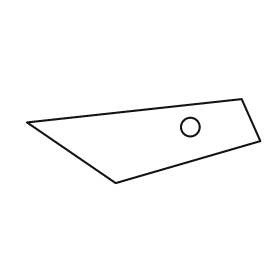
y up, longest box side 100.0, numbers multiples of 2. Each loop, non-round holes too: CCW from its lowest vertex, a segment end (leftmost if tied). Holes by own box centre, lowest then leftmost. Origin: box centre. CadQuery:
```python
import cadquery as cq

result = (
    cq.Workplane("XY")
    .moveTo(-12.0, -18.0)
    .lineTo(50.0, 0.0)
    .lineTo(42.0, 18.0)
    .lineTo(-50.0, 8.0)
    .close()
    .moveTo(20.0, 6.0)
    .circle(4.0)
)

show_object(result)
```